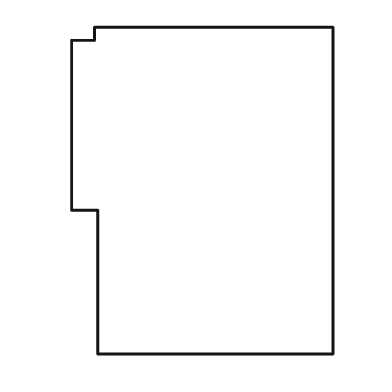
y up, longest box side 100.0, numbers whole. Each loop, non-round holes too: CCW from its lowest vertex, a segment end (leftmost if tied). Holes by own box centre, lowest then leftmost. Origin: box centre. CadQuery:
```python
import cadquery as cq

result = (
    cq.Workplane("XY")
    .moveTo(-32.0, -50.0)
    .lineTo(40.0, -50.0)
    .lineTo(40.0, 50.0)
    .lineTo(-33.0, 50.0)
    .lineTo(-33.0, 46.0)
    .lineTo(-40.0, 46.0)
    .lineTo(-40.0, -6.0)
    .lineTo(-32.0, -6.0)
    .close()
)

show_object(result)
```